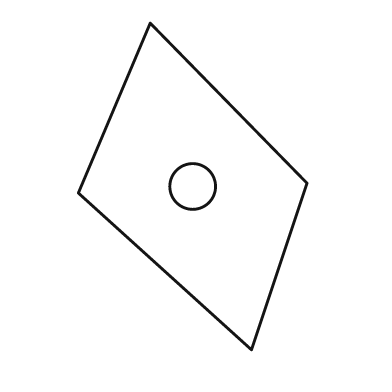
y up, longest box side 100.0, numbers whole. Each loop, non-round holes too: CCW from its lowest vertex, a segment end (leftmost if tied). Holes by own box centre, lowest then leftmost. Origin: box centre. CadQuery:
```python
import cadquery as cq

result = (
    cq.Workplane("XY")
    .moveTo(18.0, -50.0)
    .lineTo(35.0, 1.0)
    .lineTo(-13.0, 50.0)
    .lineTo(-35.0, -2.0)
    .close()
    .moveTo(0.0, 0.0)
    .circle(7.0)
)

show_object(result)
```